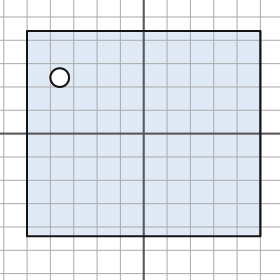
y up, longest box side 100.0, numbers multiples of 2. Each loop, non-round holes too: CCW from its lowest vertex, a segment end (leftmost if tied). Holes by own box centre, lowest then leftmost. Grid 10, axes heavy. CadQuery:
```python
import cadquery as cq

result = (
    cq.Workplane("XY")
    .moveTo(-50.0, -44.0)
    .lineTo(50.0, -44.0)
    .lineTo(50.0, 44.0)
    .lineTo(-50.0, 44.0)
    .close()
    .moveTo(-36.0, 24.0)
    .circle(4.0)
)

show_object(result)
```